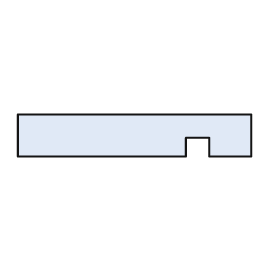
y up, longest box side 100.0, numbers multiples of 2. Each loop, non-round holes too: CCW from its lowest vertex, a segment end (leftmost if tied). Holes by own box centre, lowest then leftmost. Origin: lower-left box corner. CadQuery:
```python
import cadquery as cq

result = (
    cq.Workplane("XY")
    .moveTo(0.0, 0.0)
    .lineTo(72.0, 0.0)
    .lineTo(72.0, 8.0)
    .lineTo(82.0, 8.0)
    .lineTo(82.0, 0.0)
    .lineTo(100.0, 0.0)
    .lineTo(100.0, 18.0)
    .lineTo(0.0, 18.0)
    .close()
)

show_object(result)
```